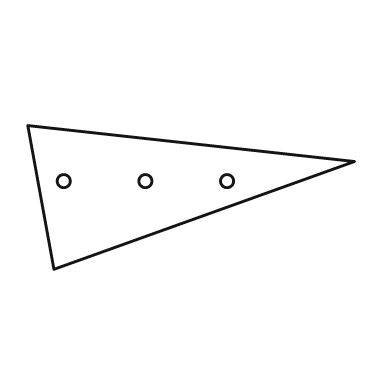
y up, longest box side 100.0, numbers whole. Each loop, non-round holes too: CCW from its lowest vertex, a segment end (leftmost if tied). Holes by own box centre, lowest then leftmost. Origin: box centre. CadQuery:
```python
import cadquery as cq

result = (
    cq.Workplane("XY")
    .moveTo(-42.0, -22.0)
    .lineTo(50.0, 11.0)
    .lineTo(-50.0, 22.0)
    .close()
    .moveTo(-39.0, 5.0)
    .circle(2.0)
    .moveTo(-14.0, 5.0)
    .circle(2.0)
    .moveTo(11.0, 5.0)
    .circle(2.0)
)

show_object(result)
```